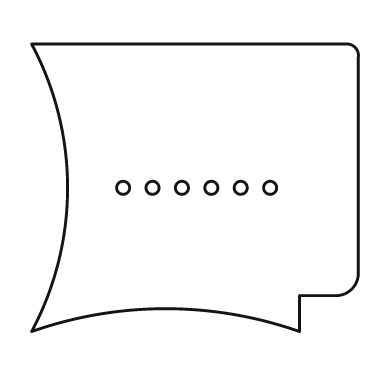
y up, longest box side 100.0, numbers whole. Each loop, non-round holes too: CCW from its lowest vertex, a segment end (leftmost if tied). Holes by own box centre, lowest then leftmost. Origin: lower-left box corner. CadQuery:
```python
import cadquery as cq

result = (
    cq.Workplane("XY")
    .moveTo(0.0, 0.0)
    .threePointArc((41.0, 7.0), (82.0, 0.0))
    .lineTo(82.0, 11.0)
    .lineTo(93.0, 11.0)
    .threePointArc((98.0, 13.0), (100.0, 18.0))
    .lineTo(100.0, 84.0)
    .threePointArc((99.0, 87.0), (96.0, 88.0))
    .lineTo(0.0, 88.0)
    .threePointArc((11.0, 44.0), (0.0, 0.0))
    .close()
    .moveTo(28.0, 44.0)
    .circle(2.0)
    .moveTo(37.0, 44.0)
    .circle(2.0)
    .moveTo(46.0, 44.0)
    .circle(2.0)
    .moveTo(55.0, 44.0)
    .circle(2.0)
    .moveTo(64.0, 44.0)
    .circle(2.0)
    .moveTo(73.0, 44.0)
    .circle(2.0)
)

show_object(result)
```